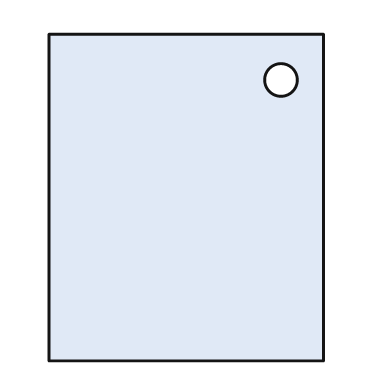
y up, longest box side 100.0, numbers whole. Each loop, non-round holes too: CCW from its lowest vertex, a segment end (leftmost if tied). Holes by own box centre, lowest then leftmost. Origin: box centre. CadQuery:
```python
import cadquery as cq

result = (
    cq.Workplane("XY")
    .moveTo(-42.0, -50.0)
    .lineTo(42.0, -50.0)
    .lineTo(42.0, 50.0)
    .lineTo(-42.0, 50.0)
    .close()
    .moveTo(29.0, 36.0)
    .circle(5.0)
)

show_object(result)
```